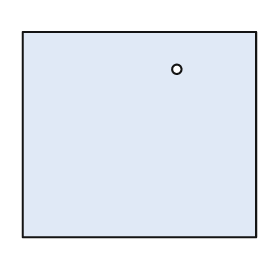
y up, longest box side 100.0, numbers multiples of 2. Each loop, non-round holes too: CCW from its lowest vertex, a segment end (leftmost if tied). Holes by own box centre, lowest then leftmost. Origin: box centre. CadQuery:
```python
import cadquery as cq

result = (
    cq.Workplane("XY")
    .moveTo(-50.0, -44.0)
    .lineTo(50.0, -44.0)
    .lineTo(50.0, 44.0)
    .lineTo(-50.0, 44.0)
    .close()
    .moveTo(16.0, 28.0)
    .circle(2.0)
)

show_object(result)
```